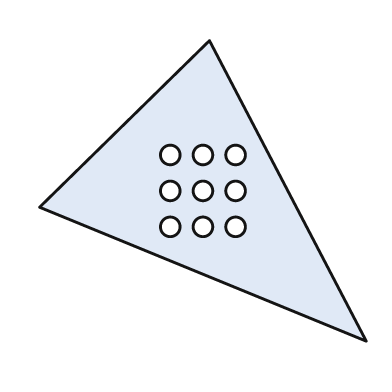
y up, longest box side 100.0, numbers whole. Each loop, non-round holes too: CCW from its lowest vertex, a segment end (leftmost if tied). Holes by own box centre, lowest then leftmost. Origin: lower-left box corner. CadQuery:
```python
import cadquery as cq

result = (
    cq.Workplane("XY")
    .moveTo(100.0, 0.0)
    .lineTo(52.0, 92.0)
    .lineTo(0.0, 41.0)
    .close()
    .moveTo(40.0, 35.0)
    .circle(3.0)
    .moveTo(50.0, 35.0)
    .circle(3.0)
    .moveTo(60.0, 35.0)
    .circle(3.0)
    .moveTo(40.0, 46.0)
    .circle(3.0)
    .moveTo(50.0, 46.0)
    .circle(3.0)
    .moveTo(60.0, 46.0)
    .circle(3.0)
    .moveTo(40.0, 57.0)
    .circle(3.0)
    .moveTo(50.0, 57.0)
    .circle(3.0)
    .moveTo(60.0, 57.0)
    .circle(3.0)
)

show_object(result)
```